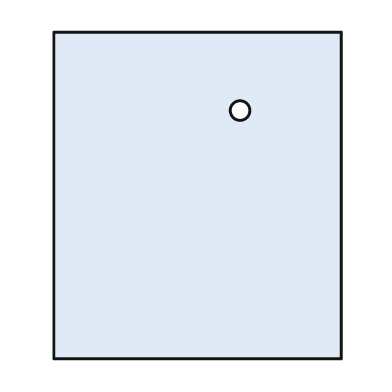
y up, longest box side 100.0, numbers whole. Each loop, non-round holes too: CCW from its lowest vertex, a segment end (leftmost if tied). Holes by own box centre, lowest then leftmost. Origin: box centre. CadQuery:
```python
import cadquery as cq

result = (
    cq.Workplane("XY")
    .moveTo(-44.0, -50.0)
    .lineTo(44.0, -50.0)
    .lineTo(44.0, 50.0)
    .lineTo(-44.0, 50.0)
    .close()
    .moveTo(13.0, 26.0)
    .circle(3.0)
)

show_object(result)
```